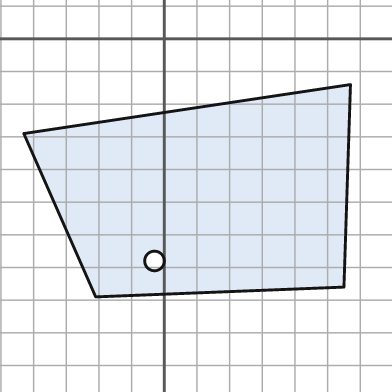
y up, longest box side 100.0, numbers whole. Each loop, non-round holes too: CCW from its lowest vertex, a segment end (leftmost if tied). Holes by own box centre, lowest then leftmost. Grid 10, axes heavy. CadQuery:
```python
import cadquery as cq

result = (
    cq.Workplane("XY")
    .moveTo(-21.0, -79.0)
    .lineTo(55.0, -76.0)
    .lineTo(57.0, -14.0)
    .lineTo(-43.0, -29.0)
    .close()
    .moveTo(-3.0, -68.0)
    .circle(3.0)
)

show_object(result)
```